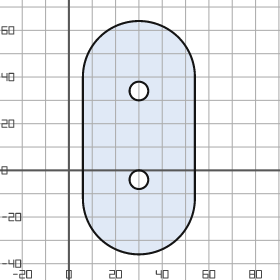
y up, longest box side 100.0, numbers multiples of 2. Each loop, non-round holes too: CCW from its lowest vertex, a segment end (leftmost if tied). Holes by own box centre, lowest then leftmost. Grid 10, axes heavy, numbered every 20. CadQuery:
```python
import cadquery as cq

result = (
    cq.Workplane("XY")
    .moveTo(6.0, -12.0)
    .threePointArc((30.0, -36.0), (54.0, -12.0))
    .lineTo(54.0, 40.0)
    .threePointArc((30.0, 64.0), (6.0, 40.0))
    .close()
    .moveTo(30.0, -4.0)
    .circle(4.0)
    .moveTo(30.0, 34.0)
    .circle(4.0)
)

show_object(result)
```